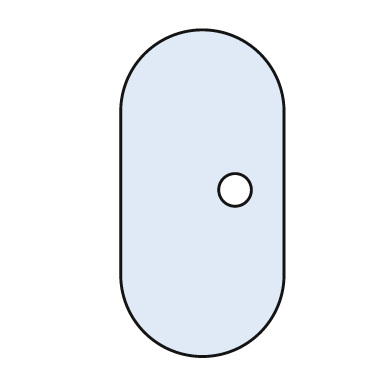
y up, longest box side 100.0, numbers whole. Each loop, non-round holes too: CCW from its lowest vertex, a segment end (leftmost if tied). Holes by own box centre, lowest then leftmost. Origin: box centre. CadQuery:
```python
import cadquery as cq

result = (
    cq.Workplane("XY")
    .moveTo(-25.0, -25.0)
    .threePointArc((0.0, -50.0), (25.0, -25.0))
    .lineTo(25.0, 25.0)
    .threePointArc((0.0, 50.0), (-25.0, 25.0))
    .close()
    .moveTo(10.0, 1.0)
    .circle(5.0)
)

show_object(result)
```